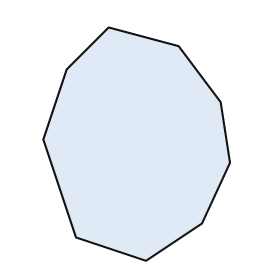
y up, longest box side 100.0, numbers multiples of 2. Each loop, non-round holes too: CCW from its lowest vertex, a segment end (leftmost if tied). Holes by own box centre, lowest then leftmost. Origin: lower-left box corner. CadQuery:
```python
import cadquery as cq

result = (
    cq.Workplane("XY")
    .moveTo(44.0, 0.0)
    .lineTo(68.0, 16.0)
    .lineTo(80.0, 42.0)
    .lineTo(76.0, 68.0)
    .lineTo(58.0, 92.0)
    .lineTo(28.0, 100.0)
    .lineTo(10.0, 82.0)
    .lineTo(0.0, 52.0)
    .lineTo(14.0, 10.0)
    .close()
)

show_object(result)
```